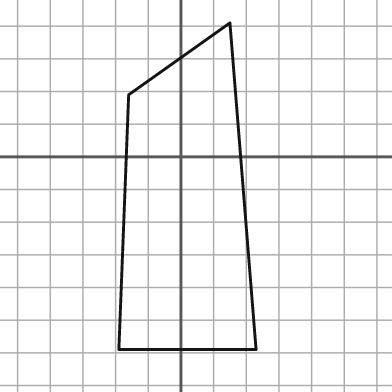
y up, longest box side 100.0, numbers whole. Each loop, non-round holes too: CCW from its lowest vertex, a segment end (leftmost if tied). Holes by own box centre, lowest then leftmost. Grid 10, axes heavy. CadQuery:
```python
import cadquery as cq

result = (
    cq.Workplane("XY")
    .moveTo(-19.0, -59.0)
    .lineTo(23.0, -59.0)
    .lineTo(15.0, 41.0)
    .lineTo(-16.0, 19.0)
    .close()
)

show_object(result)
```